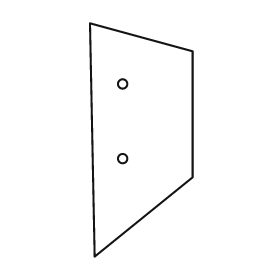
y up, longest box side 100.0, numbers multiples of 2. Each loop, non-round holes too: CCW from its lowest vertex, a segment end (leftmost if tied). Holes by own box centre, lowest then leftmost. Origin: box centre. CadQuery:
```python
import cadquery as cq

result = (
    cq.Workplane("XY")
    .moveTo(-20.0, -50.0)
    .lineTo(22.0, -16.0)
    .lineTo(22.0, 38.0)
    .lineTo(-22.0, 50.0)
    .close()
    .moveTo(-8.0, -8.0)
    .circle(2.0)
    .moveTo(-8.0, 24.0)
    .circle(2.0)
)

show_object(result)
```